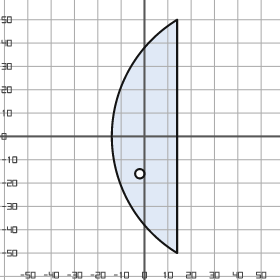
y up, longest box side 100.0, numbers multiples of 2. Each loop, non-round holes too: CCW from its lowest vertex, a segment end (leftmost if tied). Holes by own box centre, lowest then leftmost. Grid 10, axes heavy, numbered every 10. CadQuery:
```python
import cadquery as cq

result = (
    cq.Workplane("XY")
    .moveTo(14.0, -50.0)
    .lineTo(14.0, 50.0)
    .threePointArc((-14.0, 0.0), (14.0, -50.0))
    .close()
    .moveTo(-2.0, -16.0)
    .circle(2.0)
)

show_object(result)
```